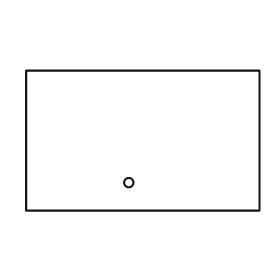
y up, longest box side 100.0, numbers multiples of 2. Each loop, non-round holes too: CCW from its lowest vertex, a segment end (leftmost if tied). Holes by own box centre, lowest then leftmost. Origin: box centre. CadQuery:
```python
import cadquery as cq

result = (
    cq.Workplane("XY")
    .moveTo(-50.0, -30.0)
    .lineTo(50.0, -30.0)
    .lineTo(50.0, 30.0)
    .lineTo(-50.0, 30.0)
    .close()
    .moveTo(-6.0, -18.0)
    .circle(2.0)
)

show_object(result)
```